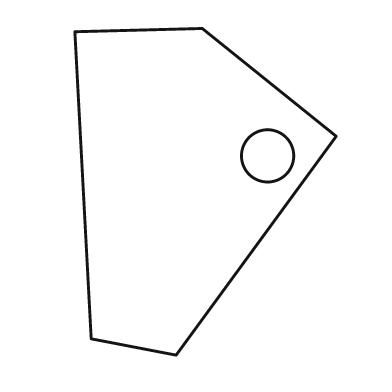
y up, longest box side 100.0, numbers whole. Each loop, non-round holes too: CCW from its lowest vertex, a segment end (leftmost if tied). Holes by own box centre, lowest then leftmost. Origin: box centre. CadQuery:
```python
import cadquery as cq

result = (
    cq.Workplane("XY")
    .moveTo(-9.0, -50.0)
    .lineTo(40.0, 17.0)
    .lineTo(-1.0, 50.0)
    .lineTo(-40.0, 49.0)
    .lineTo(-35.0, -45.0)
    .close()
    .moveTo(19.0, 11.0)
    .circle(8.0)
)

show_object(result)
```